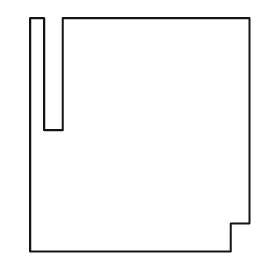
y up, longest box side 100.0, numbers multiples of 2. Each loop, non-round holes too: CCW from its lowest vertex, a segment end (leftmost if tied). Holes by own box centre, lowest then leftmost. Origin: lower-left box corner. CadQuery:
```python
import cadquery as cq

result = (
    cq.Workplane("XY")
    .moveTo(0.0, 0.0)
    .lineTo(86.0, 0.0)
    .lineTo(86.0, 12.0)
    .lineTo(94.0, 12.0)
    .lineTo(94.0, 100.0)
    .lineTo(14.0, 100.0)
    .lineTo(14.0, 52.0)
    .lineTo(6.0, 52.0)
    .lineTo(6.0, 100.0)
    .lineTo(0.0, 100.0)
    .close()
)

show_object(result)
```